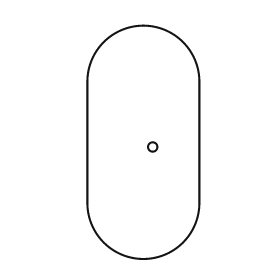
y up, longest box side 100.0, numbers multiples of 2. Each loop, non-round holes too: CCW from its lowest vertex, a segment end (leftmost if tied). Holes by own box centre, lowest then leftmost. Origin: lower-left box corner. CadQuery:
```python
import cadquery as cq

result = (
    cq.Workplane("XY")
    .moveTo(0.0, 24.0)
    .threePointArc((24.0, 0.0), (48.0, 24.0))
    .lineTo(48.0, 76.0)
    .threePointArc((24.0, 100.0), (0.0, 76.0))
    .close()
    .moveTo(28.0, 48.0)
    .circle(2.0)
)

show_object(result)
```